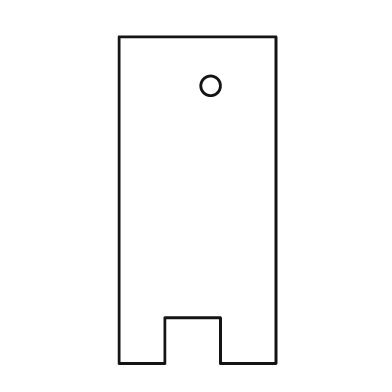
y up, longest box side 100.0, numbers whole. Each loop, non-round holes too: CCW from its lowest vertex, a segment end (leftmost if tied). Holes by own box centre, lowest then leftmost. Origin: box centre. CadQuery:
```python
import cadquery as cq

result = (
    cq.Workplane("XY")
    .moveTo(-24.0, -50.0)
    .lineTo(-10.0, -50.0)
    .lineTo(-10.0, -36.0)
    .lineTo(7.0, -36.0)
    .lineTo(7.0, -50.0)
    .lineTo(24.0, -50.0)
    .lineTo(24.0, 50.0)
    .lineTo(-24.0, 50.0)
    .close()
    .moveTo(4.0, 35.0)
    .circle(3.0)
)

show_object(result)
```